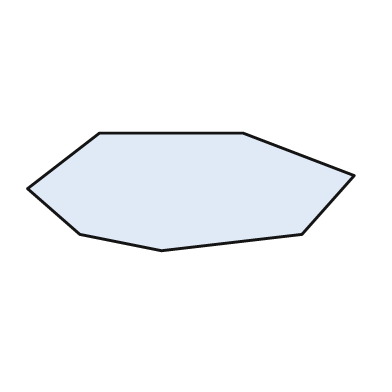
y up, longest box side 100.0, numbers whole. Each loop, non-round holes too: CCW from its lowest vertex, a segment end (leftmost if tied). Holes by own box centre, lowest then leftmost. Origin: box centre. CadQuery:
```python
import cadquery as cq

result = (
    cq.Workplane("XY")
    .moveTo(-9.0, -18.0)
    .lineTo(34.0, -13.0)
    .lineTo(50.0, 5.0)
    .lineTo(16.0, 18.0)
    .lineTo(-28.0, 18.0)
    .lineTo(-50.0, 1.0)
    .lineTo(-34.0, -13.0)
    .close()
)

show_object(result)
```